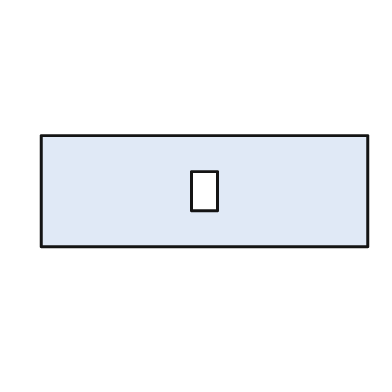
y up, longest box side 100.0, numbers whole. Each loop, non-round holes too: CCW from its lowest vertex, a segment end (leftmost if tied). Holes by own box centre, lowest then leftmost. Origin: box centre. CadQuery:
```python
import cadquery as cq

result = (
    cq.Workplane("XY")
    .moveTo(-50.0, -17.0)
    .lineTo(50.0, -17.0)
    .lineTo(50.0, 17.0)
    .lineTo(-50.0, 17.0)
    .close()
    .moveTo(-4.0, -6.0)
    .lineTo(4.0, -6.0)
    .lineTo(4.0, 6.0)
    .lineTo(-4.0, 6.0)
    .close()
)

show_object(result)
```